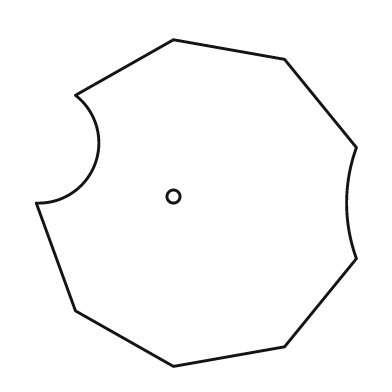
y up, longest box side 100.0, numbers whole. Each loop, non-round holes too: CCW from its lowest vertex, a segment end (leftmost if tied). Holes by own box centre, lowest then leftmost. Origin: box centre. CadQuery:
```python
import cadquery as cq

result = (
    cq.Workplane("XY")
    .moveTo(-7.0, -50.0)
    .lineTo(27.0, -44.0)
    .lineTo(49.0, -17.0)
    .threePointArc((46.0, 0.0), (49.0, 17.0))
    .lineTo(27.0, 44.0)
    .lineTo(-7.0, 50.0)
    .lineTo(-37.0, 33.0)
    .threePointArc((-31.0, 12.0), (-49.0, 0.0))
    .lineTo(-37.0, -33.0)
    .close()
    .moveTo(-7.0, 2.0)
    .circle(2.0)
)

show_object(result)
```